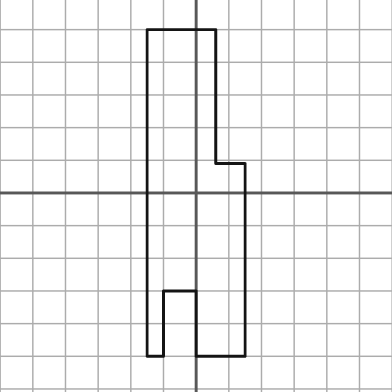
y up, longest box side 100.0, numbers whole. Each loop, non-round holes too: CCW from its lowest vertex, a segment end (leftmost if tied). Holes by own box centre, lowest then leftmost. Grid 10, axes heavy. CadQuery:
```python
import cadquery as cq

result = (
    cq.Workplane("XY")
    .moveTo(-15.0, -50.0)
    .lineTo(-10.0, -50.0)
    .lineTo(-10.0, -30.0)
    .lineTo(0.0, -30.0)
    .lineTo(0.0, -50.0)
    .lineTo(15.0, -50.0)
    .lineTo(15.0, 9.0)
    .lineTo(6.0, 9.0)
    .lineTo(6.0, 50.0)
    .lineTo(-15.0, 50.0)
    .close()
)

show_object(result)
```